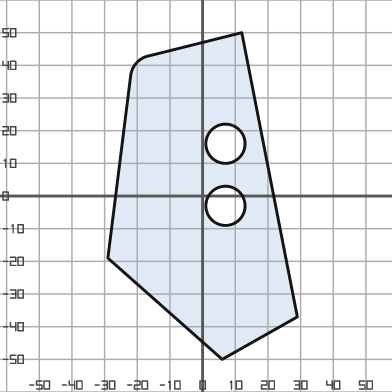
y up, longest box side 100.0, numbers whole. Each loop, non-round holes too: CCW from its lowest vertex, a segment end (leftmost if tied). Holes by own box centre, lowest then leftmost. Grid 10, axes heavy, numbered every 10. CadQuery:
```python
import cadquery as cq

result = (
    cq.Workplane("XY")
    .moveTo(6.0, -50.0)
    .lineTo(29.0, -37.0)
    .lineTo(12.0, 50.0)
    .lineTo(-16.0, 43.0)
    .threePointArc((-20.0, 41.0), (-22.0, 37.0))
    .lineTo(-29.0, -19.0)
    .close()
    .moveTo(7.0, -3.0)
    .circle(6.0)
    .moveTo(7.0, 16.0)
    .circle(6.0)
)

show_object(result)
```